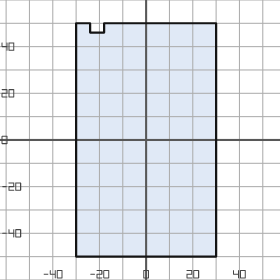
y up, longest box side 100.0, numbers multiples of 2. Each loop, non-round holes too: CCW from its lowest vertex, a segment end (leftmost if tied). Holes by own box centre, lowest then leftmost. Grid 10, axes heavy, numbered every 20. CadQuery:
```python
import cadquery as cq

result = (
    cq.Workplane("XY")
    .moveTo(-30.0, -50.0)
    .lineTo(30.0, -50.0)
    .lineTo(30.0, 50.0)
    .lineTo(-18.0, 50.0)
    .lineTo(-18.0, 46.0)
    .lineTo(-24.0, 46.0)
    .lineTo(-24.0, 50.0)
    .lineTo(-30.0, 50.0)
    .close()
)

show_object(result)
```